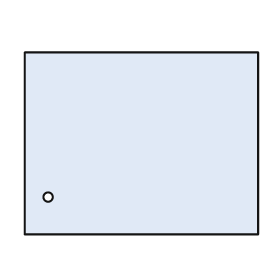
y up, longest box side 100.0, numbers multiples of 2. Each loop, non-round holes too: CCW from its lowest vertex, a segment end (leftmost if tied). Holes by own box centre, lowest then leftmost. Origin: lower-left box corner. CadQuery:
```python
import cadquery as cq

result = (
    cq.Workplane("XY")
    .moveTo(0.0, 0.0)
    .lineTo(100.0, 0.0)
    .lineTo(100.0, 78.0)
    .lineTo(0.0, 78.0)
    .close()
    .moveTo(10.0, 16.0)
    .circle(2.0)
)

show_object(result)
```